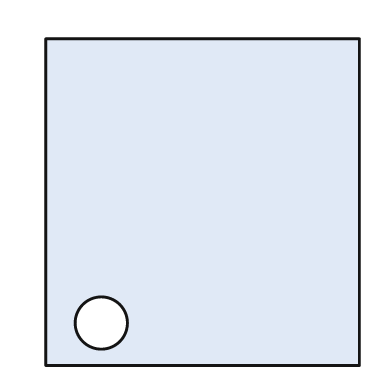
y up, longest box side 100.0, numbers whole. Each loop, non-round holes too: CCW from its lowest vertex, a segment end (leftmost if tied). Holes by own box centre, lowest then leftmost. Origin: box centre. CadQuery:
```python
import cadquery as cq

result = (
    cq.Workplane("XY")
    .moveTo(-48.0, -50.0)
    .lineTo(48.0, -50.0)
    .lineTo(48.0, 50.0)
    .lineTo(-48.0, 50.0)
    .close()
    .moveTo(-31.0, -37.0)
    .circle(8.0)
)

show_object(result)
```